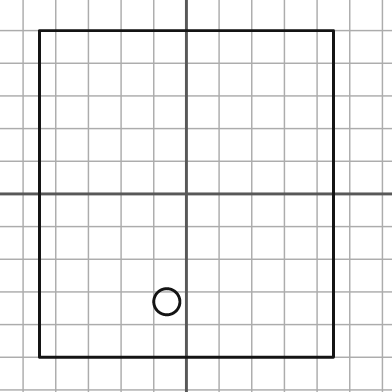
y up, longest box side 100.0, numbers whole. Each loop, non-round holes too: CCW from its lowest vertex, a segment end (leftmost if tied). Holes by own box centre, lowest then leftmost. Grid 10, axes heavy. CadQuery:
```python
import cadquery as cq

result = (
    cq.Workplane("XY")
    .moveTo(-45.0, -50.0)
    .lineTo(45.0, -50.0)
    .lineTo(45.0, 50.0)
    .lineTo(-45.0, 50.0)
    .close()
    .moveTo(-6.0, -33.0)
    .circle(4.0)
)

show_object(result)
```